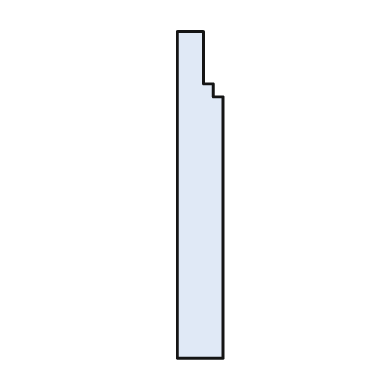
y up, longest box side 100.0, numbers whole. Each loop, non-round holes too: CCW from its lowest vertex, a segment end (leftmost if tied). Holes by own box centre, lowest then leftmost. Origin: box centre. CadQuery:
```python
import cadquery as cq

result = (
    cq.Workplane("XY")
    .moveTo(-7.0, -50.0)
    .lineTo(7.0, -50.0)
    .lineTo(7.0, 30.0)
    .lineTo(4.0, 30.0)
    .lineTo(4.0, 34.0)
    .lineTo(1.0, 34.0)
    .lineTo(1.0, 50.0)
    .lineTo(-7.0, 50.0)
    .close()
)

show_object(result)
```